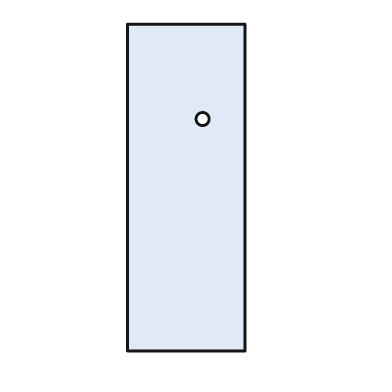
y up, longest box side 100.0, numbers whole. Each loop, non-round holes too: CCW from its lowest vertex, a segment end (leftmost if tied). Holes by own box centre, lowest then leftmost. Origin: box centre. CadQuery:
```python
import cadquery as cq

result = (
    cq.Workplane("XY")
    .moveTo(-18.0, -50.0)
    .lineTo(18.0, -50.0)
    .lineTo(18.0, 50.0)
    .lineTo(-18.0, 50.0)
    .close()
    .moveTo(5.0, 21.0)
    .circle(2.0)
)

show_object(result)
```